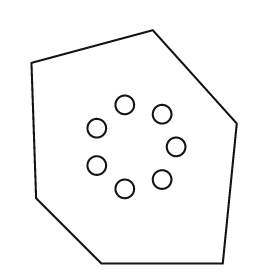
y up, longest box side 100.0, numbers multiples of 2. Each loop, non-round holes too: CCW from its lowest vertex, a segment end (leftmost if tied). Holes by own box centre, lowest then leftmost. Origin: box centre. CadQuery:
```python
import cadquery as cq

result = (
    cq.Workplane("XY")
    .moveTo(-14.0, -50.0)
    .lineTo(38.0, -50.0)
    .lineTo(44.0, 10.0)
    .lineTo(8.0, 50.0)
    .lineTo(-44.0, 36.0)
    .lineTo(-42.0, -22.0)
    .close()
    .moveTo(-4.0, -18.0)
    .circle(4.0)
    .moveTo(12.0, -14.0)
    .circle(4.0)
    .moveTo(-16.0, -8.0)
    .circle(4.0)
    .moveTo(18.0, 0.0)
    .circle(4.0)
    .moveTo(-16.0, 8.0)
    .circle(4.0)
    .moveTo(12.0, 14.0)
    .circle(4.0)
    .moveTo(-4.0, 18.0)
    .circle(4.0)
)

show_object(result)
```